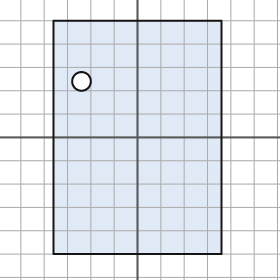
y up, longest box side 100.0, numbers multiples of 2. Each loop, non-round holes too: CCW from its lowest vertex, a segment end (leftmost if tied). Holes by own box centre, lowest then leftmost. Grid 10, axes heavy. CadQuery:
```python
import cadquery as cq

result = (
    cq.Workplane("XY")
    .moveTo(-36.0, -50.0)
    .lineTo(36.0, -50.0)
    .lineTo(36.0, 50.0)
    .lineTo(-36.0, 50.0)
    .close()
    .moveTo(-24.0, 24.0)
    .circle(4.0)
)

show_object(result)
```